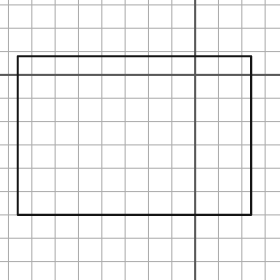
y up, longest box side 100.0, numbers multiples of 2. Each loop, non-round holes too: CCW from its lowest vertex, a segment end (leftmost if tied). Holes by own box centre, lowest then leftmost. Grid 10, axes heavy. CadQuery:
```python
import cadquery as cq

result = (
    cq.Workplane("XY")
    .moveTo(-76.0, -60.0)
    .lineTo(24.0, -60.0)
    .lineTo(24.0, 8.0)
    .lineTo(-76.0, 8.0)
    .close()
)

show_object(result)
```